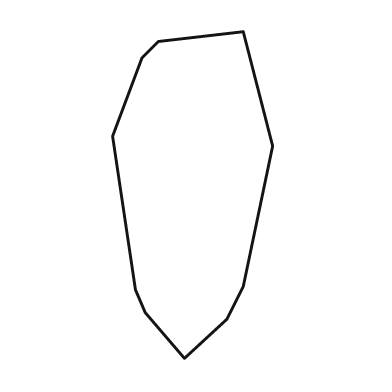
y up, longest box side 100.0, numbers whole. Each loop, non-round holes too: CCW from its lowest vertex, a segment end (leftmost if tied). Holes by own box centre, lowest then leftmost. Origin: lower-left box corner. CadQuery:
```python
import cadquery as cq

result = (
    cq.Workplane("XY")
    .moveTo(22.0, 0.0)
    .lineTo(35.0, 12.0)
    .lineTo(40.0, 22.0)
    .lineTo(49.0, 65.0)
    .lineTo(40.0, 100.0)
    .lineTo(14.0, 97.0)
    .lineTo(9.0, 92.0)
    .lineTo(0.0, 68.0)
    .lineTo(7.0, 21.0)
    .lineTo(10.0, 14.0)
    .close()
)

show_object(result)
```